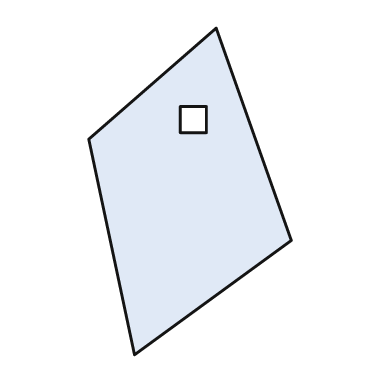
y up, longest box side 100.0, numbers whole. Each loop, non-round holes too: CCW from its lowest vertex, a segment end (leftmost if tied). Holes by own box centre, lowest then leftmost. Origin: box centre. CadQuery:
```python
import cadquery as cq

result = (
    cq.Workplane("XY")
    .moveTo(-17.0, -50.0)
    .lineTo(31.0, -15.0)
    .lineTo(8.0, 50.0)
    .lineTo(-31.0, 16.0)
    .close()
    .moveTo(-3.0, 18.0)
    .lineTo(5.0, 18.0)
    .lineTo(5.0, 26.0)
    .lineTo(-3.0, 26.0)
    .close()
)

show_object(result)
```